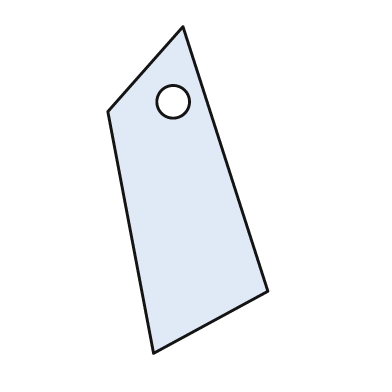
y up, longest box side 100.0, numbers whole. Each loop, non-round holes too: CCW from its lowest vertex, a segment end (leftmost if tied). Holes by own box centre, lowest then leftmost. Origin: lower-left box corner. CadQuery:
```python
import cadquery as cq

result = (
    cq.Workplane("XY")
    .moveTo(14.0, 0.0)
    .lineTo(49.0, 19.0)
    .lineTo(23.0, 100.0)
    .lineTo(0.0, 74.0)
    .close()
    .moveTo(20.0, 77.0)
    .circle(5.0)
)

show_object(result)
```